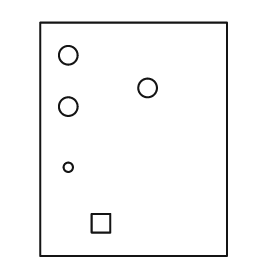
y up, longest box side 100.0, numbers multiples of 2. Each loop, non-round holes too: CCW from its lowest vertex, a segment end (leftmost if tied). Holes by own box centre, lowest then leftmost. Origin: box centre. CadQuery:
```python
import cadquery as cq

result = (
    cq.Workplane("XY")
    .moveTo(-40.0, -50.0)
    .lineTo(40.0, -50.0)
    .lineTo(40.0, 50.0)
    .lineTo(-40.0, 50.0)
    .close()
    .moveTo(-18.0, -40.0)
    .lineTo(-10.0, -40.0)
    .lineTo(-10.0, -32.0)
    .lineTo(-18.0, -32.0)
    .close()
    .moveTo(-28.0, -12.0)
    .circle(2.0)
    .moveTo(-28.0, 14.0)
    .circle(4.0)
    .moveTo(6.0, 22.0)
    .circle(4.0)
    .moveTo(-28.0, 36.0)
    .circle(4.0)
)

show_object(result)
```